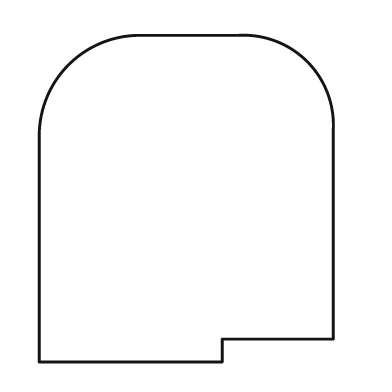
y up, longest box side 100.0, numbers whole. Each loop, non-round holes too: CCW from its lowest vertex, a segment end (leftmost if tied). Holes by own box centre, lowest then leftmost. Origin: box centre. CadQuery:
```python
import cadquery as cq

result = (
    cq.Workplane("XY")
    .moveTo(-45.0, -50.0)
    .lineTo(11.0, -50.0)
    .lineTo(11.0, -43.0)
    .lineTo(45.0, -43.0)
    .lineTo(45.0, 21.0)
    .threePointArc((37.0, 42.0), (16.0, 50.0))
    .lineTo(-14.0, 50.0)
    .threePointArc((-36.0, 41.0), (-45.0, 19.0))
    .close()
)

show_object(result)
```